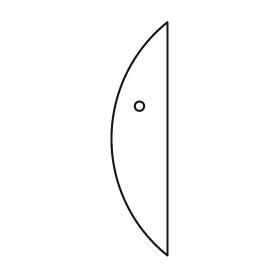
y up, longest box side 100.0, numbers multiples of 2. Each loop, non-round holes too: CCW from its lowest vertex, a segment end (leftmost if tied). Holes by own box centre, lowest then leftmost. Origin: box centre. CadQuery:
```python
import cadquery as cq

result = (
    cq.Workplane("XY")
    .moveTo(12.0, -50.0)
    .lineTo(12.0, 50.0)
    .threePointArc((-12.0, 0.0), (12.0, -50.0))
    .close()
    .moveTo(0.0, 14.0)
    .circle(2.0)
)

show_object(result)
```